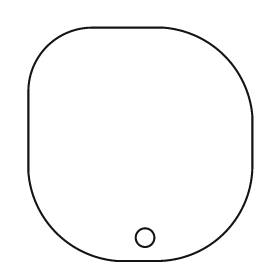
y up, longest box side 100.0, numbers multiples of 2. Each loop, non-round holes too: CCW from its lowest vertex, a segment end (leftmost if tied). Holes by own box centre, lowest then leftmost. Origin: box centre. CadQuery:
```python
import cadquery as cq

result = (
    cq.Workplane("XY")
    .moveTo(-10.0, -50.0)
    .lineTo(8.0, -50.0)
    .threePointArc((36.0, -38.0), (48.0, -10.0))
    .lineTo(48.0, 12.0)
    .threePointArc((36.0, 38.0), (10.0, 50.0))
    .lineTo(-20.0, 50.0)
    .threePointArc((-40.0, 42.0), (-48.0, 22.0))
    .lineTo(-48.0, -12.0)
    .threePointArc((-36.0, -38.0), (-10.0, -50.0))
    .close()
    .moveTo(2.0, -40.0)
    .circle(4.0)
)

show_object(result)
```